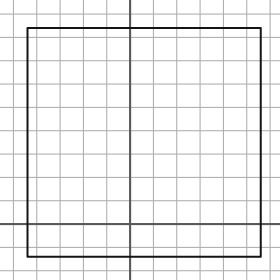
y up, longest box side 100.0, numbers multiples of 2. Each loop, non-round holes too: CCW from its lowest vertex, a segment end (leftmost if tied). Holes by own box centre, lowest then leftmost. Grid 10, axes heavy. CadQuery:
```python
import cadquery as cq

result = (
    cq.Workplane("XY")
    .moveTo(-44.0, -14.0)
    .lineTo(56.0, -14.0)
    .lineTo(56.0, 84.0)
    .lineTo(-44.0, 84.0)
    .close()
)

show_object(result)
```